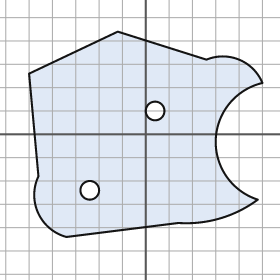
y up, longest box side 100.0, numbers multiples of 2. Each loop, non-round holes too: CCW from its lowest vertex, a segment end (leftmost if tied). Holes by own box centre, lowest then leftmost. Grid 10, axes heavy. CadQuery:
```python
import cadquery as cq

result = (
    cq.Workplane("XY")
    .moveTo(-34.0, -44.0)
    .lineTo(14.0, -38.0)
    .threePointArc((32.0, -36.0), (48.0, -28.0))
    .threePointArc((30.0, -2.0), (50.0, 22.0))
    .threePointArc((40.0, 32.0), (26.0, 32.0))
    .lineTo(-12.0, 44.0)
    .lineTo(-50.0, 26.0)
    .lineTo(-46.0, -18.0)
    .threePointArc((-46.0, -34.0), (-34.0, -44.0))
    .close()
    .moveTo(-24.0, -24.0)
    .circle(4.0)
    .moveTo(4.0, 10.0)
    .circle(4.0)
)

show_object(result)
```